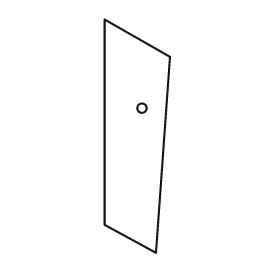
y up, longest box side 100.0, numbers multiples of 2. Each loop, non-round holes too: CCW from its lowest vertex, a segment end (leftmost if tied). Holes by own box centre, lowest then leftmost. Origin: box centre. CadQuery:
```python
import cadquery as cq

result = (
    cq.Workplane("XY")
    .moveTo(8.0, -50.0)
    .lineTo(14.0, 34.0)
    .lineTo(-14.0, 50.0)
    .lineTo(-14.0, -38.0)
    .close()
    .moveTo(2.0, 12.0)
    .circle(2.0)
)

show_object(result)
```